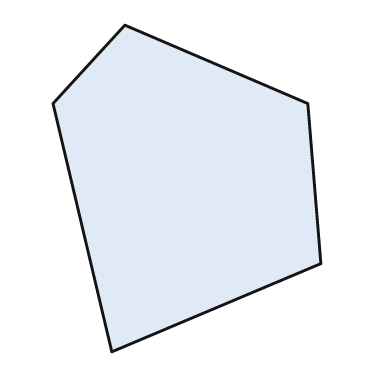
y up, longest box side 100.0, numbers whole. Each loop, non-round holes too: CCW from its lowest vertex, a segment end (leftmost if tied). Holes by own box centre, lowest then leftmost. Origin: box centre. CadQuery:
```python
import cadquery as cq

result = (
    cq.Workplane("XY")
    .moveTo(-23.0, -50.0)
    .lineTo(41.0, -23.0)
    .lineTo(37.0, 26.0)
    .lineTo(-19.0, 50.0)
    .lineTo(-41.0, 26.0)
    .close()
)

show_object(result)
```